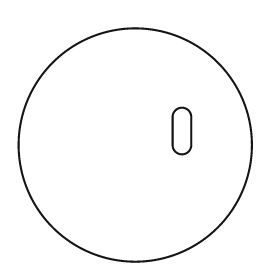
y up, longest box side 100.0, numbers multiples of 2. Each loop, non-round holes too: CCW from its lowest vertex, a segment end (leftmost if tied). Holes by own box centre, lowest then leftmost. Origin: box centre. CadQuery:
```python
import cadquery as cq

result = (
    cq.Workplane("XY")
    .moveTo(0.0, 0.0)
    .circle(50.0)
    .moveTo(16.0, 0.0)
    .threePointArc((20.0, -4.0), (24.0, 0.0))
    .lineTo(24.0, 12.0)
    .threePointArc((20.0, 16.0), (16.0, 12.0))
    .close()
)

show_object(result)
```